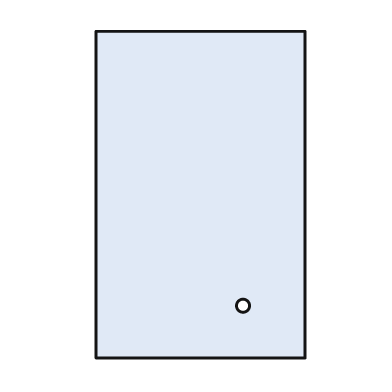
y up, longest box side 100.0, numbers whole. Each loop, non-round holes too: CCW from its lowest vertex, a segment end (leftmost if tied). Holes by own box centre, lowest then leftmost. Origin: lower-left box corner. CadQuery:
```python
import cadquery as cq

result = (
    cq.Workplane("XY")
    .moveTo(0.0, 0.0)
    .lineTo(64.0, 0.0)
    .lineTo(64.0, 100.0)
    .lineTo(0.0, 100.0)
    .close()
    .moveTo(45.0, 16.0)
    .circle(2.0)
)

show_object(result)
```